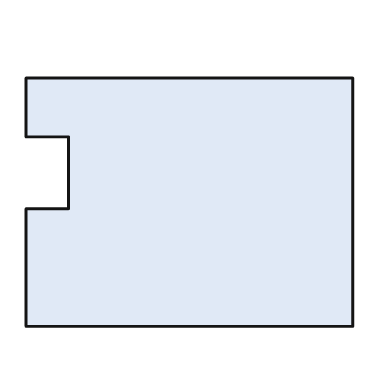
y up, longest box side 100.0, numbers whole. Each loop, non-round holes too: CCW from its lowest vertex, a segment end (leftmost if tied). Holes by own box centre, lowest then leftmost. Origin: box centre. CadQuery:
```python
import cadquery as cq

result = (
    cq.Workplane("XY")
    .moveTo(-50.0, -38.0)
    .lineTo(50.0, -38.0)
    .lineTo(50.0, 38.0)
    .lineTo(-50.0, 38.0)
    .lineTo(-50.0, 20.0)
    .lineTo(-37.0, 20.0)
    .lineTo(-37.0, -2.0)
    .lineTo(-50.0, -2.0)
    .close()
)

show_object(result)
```